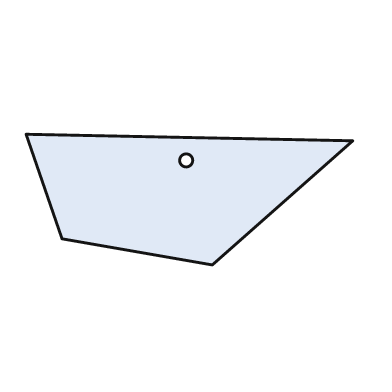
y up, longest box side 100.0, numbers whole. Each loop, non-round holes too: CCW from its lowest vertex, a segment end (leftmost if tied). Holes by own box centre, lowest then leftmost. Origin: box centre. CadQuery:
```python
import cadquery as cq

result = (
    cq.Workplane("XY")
    .moveTo(7.0, -20.0)
    .lineTo(50.0, 18.0)
    .lineTo(-50.0, 20.0)
    .lineTo(-39.0, -12.0)
    .close()
    .moveTo(-1.0, 12.0)
    .circle(2.0)
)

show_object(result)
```